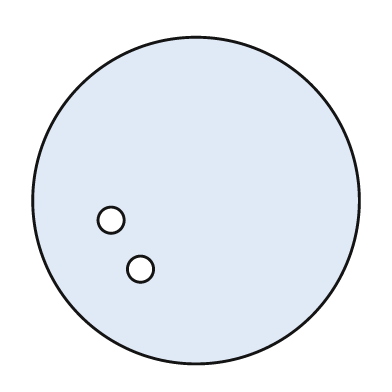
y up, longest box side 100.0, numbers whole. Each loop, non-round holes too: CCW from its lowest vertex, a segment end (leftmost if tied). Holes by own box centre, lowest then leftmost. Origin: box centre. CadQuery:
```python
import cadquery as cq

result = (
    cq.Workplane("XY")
    .moveTo(0.0, 0.0)
    .circle(50.0)
    .moveTo(-17.0, -21.0)
    .circle(4.0)
    .moveTo(-26.0, -6.0)
    .circle(4.0)
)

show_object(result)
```